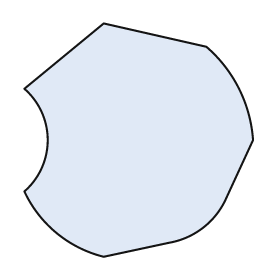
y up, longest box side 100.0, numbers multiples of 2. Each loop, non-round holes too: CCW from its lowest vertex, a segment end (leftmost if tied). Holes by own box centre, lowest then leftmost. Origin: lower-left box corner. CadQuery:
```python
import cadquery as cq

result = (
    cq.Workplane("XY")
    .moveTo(34.0, 0.0)
    .lineTo(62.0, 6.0)
    .threePointArc((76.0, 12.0), (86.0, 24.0))
    .lineTo(98.0, 50.0)
    .threePointArc((92.0, 72.0), (78.0, 90.0))
    .lineTo(34.0, 100.0)
    .lineTo(0.0, 72.0)
    .threePointArc((10.0, 50.0), (0.0, 28.0))
    .threePointArc((14.0, 10.0), (34.0, 0.0))
    .close()
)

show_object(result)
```